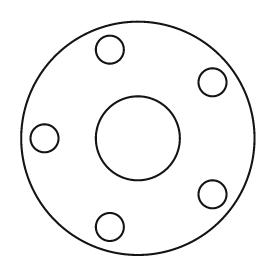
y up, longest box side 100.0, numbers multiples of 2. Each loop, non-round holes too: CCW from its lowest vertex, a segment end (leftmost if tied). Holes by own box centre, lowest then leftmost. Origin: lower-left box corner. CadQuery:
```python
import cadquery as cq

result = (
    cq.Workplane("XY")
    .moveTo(50.0, 50.0)
    .circle(50.0)
    .moveTo(38.0, 12.0)
    .circle(6.0)
    .moveTo(82.0, 26.0)
    .circle(6.0)
    .moveTo(10.0, 50.0)
    .circle(6.0)
    .moveTo(50.0, 50.0)
    .circle(18.0)
    .moveTo(82.0, 74.0)
    .circle(6.0)
    .moveTo(38.0, 88.0)
    .circle(6.0)
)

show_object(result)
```